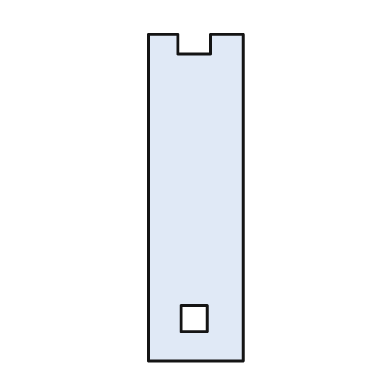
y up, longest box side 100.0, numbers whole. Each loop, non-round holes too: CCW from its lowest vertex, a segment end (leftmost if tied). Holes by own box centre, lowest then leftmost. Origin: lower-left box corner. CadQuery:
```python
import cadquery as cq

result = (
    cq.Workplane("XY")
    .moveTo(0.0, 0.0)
    .lineTo(29.0, 0.0)
    .lineTo(29.0, 100.0)
    .lineTo(19.0, 100.0)
    .lineTo(19.0, 94.0)
    .lineTo(9.0, 94.0)
    .lineTo(9.0, 100.0)
    .lineTo(0.0, 100.0)
    .close()
    .moveTo(10.0, 9.0)
    .lineTo(18.0, 9.0)
    .lineTo(18.0, 17.0)
    .lineTo(10.0, 17.0)
    .close()
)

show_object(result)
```